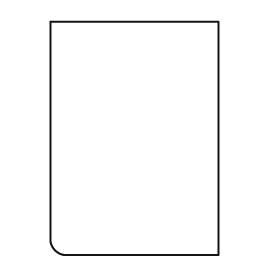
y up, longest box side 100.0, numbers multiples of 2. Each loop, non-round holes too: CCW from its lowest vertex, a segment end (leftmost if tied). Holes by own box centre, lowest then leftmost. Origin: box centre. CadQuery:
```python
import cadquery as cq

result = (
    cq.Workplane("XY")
    .moveTo(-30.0, -50.0)
    .lineTo(36.0, -50.0)
    .lineTo(36.0, 50.0)
    .lineTo(-36.0, 50.0)
    .lineTo(-36.0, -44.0)
    .threePointArc((-34.0, -48.0), (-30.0, -50.0))
    .close()
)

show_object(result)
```